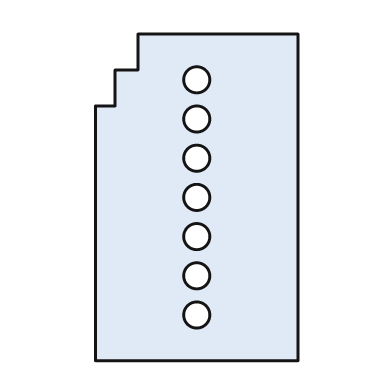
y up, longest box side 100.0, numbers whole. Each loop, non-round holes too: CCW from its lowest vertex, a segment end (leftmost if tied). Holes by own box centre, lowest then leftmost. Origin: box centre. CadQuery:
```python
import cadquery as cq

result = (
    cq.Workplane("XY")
    .moveTo(-31.0, -50.0)
    .lineTo(31.0, -50.0)
    .lineTo(31.0, 50.0)
    .lineTo(-18.0, 50.0)
    .lineTo(-18.0, 39.0)
    .lineTo(-25.0, 39.0)
    .lineTo(-25.0, 28.0)
    .lineTo(-31.0, 28.0)
    .close()
    .moveTo(0.0, -36.0)
    .circle(4.0)
    .moveTo(0.0, -24.0)
    .circle(4.0)
    .moveTo(0.0, -12.0)
    .circle(4.0)
    .moveTo(0.0, 0.0)
    .circle(4.0)
    .moveTo(0.0, 12.0)
    .circle(4.0)
    .moveTo(0.0, 24.0)
    .circle(4.0)
    .moveTo(0.0, 36.0)
    .circle(4.0)
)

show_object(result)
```